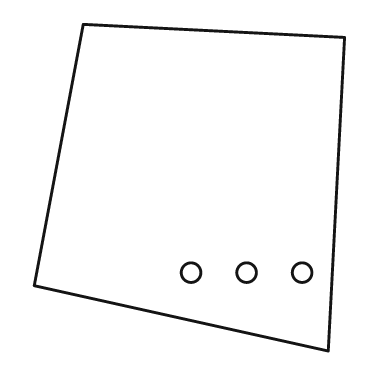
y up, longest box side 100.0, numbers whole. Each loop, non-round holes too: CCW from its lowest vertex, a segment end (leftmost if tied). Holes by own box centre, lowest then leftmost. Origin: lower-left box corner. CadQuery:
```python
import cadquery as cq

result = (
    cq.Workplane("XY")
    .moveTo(90.0, 0.0)
    .lineTo(95.0, 96.0)
    .lineTo(15.0, 100.0)
    .lineTo(0.0, 20.0)
    .close()
    .moveTo(48.0, 24.0)
    .circle(3.0)
    .moveTo(65.0, 24.0)
    .circle(3.0)
    .moveTo(82.0, 24.0)
    .circle(3.0)
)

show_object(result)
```